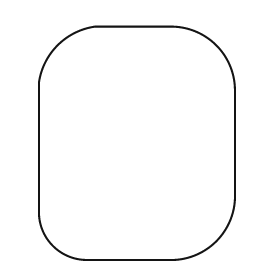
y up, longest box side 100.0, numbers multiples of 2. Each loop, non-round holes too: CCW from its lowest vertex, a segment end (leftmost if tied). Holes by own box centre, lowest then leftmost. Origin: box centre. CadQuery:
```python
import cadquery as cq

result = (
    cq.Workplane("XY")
    .moveTo(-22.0, -50.0)
    .lineTo(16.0, -50.0)
    .threePointArc((34.0, -42.0), (42.0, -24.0))
    .lineTo(42.0, 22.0)
    .threePointArc((34.0, 42.0), (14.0, 50.0))
    .lineTo(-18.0, 50.0)
    .threePointArc((-34.0, 42.0), (-42.0, 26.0))
    .lineTo(-42.0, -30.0)
    .threePointArc((-36.0, -44.0), (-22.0, -50.0))
    .close()
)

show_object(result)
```